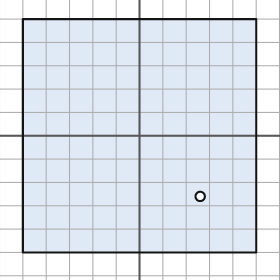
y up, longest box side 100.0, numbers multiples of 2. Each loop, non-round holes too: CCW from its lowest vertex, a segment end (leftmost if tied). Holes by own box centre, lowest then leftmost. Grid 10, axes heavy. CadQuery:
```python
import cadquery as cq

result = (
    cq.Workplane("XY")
    .moveTo(-50.0, -50.0)
    .lineTo(50.0, -50.0)
    .lineTo(50.0, 50.0)
    .lineTo(-50.0, 50.0)
    .close()
    .moveTo(26.0, -26.0)
    .circle(2.0)
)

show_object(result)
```